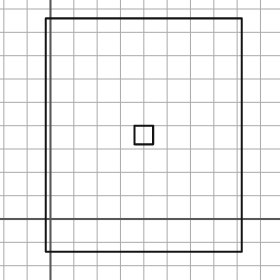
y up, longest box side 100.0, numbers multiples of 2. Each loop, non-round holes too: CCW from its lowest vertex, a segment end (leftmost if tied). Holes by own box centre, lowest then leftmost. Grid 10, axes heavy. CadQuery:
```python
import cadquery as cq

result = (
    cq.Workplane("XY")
    .moveTo(-2.0, -14.0)
    .lineTo(82.0, -14.0)
    .lineTo(82.0, 86.0)
    .lineTo(-2.0, 86.0)
    .close()
    .moveTo(36.0, 32.0)
    .lineTo(44.0, 32.0)
    .lineTo(44.0, 40.0)
    .lineTo(36.0, 40.0)
    .close()
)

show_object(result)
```